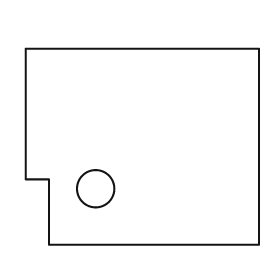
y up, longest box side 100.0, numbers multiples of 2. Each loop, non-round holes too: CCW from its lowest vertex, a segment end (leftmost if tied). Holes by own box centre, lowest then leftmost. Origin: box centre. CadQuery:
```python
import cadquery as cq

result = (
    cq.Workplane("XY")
    .moveTo(-40.0, -42.0)
    .lineTo(50.0, -42.0)
    .lineTo(50.0, 42.0)
    .lineTo(-50.0, 42.0)
    .lineTo(-50.0, -14.0)
    .lineTo(-40.0, -14.0)
    .close()
    .moveTo(-20.0, -18.0)
    .circle(8.0)
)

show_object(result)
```